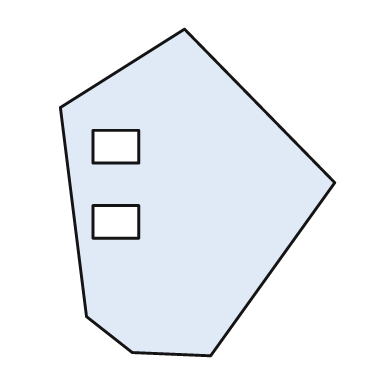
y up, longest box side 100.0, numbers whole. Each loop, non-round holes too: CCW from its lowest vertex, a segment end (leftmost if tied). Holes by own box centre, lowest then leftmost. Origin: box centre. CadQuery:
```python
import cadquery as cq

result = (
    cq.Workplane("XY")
    .moveTo(4.0, -50.0)
    .lineTo(42.0, 3.0)
    .lineTo(-4.0, 50.0)
    .lineTo(-42.0, 26.0)
    .lineTo(-34.0, -38.0)
    .lineTo(-20.0, -49.0)
    .close()
    .moveTo(-32.0, -14.0)
    .lineTo(-18.0, -14.0)
    .lineTo(-18.0, -4.0)
    .lineTo(-32.0, -4.0)
    .close()
    .moveTo(-32.0, 9.0)
    .lineTo(-18.0, 9.0)
    .lineTo(-18.0, 19.0)
    .lineTo(-32.0, 19.0)
    .close()
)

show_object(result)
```